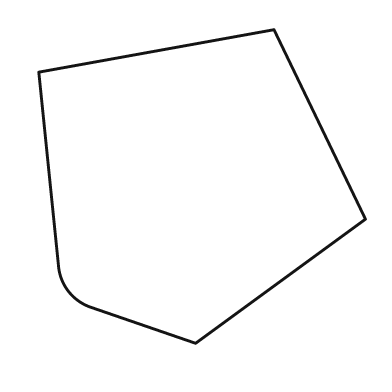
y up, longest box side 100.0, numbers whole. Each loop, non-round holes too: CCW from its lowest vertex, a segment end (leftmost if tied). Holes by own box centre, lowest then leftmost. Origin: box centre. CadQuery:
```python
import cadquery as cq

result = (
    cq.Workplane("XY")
    .moveTo(-2.0, -48.0)
    .lineTo(50.0, -10.0)
    .lineTo(22.0, 48.0)
    .lineTo(-50.0, 35.0)
    .lineTo(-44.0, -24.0)
    .threePointArc((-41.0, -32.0), (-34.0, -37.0))
    .close()
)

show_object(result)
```